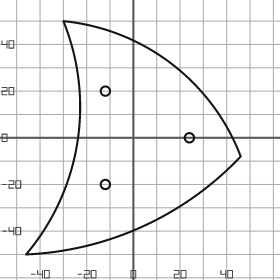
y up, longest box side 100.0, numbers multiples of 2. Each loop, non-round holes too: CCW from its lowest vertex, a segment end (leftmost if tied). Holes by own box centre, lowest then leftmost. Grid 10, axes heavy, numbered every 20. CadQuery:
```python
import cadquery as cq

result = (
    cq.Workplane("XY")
    .moveTo(-46.0, -50.0)
    .threePointArc((4.0, -38.0), (46.0, -8.0))
    .threePointArc((16.0, 32.0), (-30.0, 50.0))
    .threePointArc((-24.0, -2.0), (-46.0, -50.0))
    .close()
    .moveTo(-12.0, -20.0)
    .circle(2.0)
    .moveTo(24.0, 0.0)
    .circle(2.0)
    .moveTo(-12.0, 20.0)
    .circle(2.0)
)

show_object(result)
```